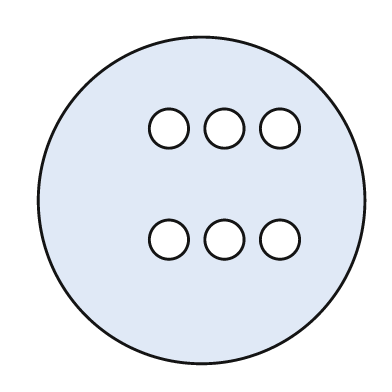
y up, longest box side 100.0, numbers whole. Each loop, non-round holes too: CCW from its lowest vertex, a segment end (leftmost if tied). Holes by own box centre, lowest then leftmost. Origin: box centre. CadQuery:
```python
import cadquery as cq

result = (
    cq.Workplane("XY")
    .moveTo(0.0, 0.0)
    .circle(50.0)
    .moveTo(-10.0, -12.0)
    .circle(6.0)
    .moveTo(7.0, -12.0)
    .circle(6.0)
    .moveTo(24.0, -12.0)
    .circle(6.0)
    .moveTo(-10.0, 22.0)
    .circle(6.0)
    .moveTo(7.0, 22.0)
    .circle(6.0)
    .moveTo(24.0, 22.0)
    .circle(6.0)
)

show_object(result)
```